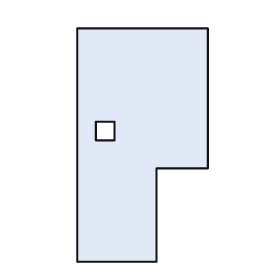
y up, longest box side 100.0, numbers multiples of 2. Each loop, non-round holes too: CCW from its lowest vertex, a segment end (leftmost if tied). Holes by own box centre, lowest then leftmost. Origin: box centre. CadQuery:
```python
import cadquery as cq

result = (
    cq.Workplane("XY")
    .moveTo(-28.0, -50.0)
    .lineTo(6.0, -50.0)
    .lineTo(6.0, -10.0)
    .lineTo(28.0, -10.0)
    .lineTo(28.0, 50.0)
    .lineTo(-28.0, 50.0)
    .close()
    .moveTo(-20.0, 2.0)
    .lineTo(-12.0, 2.0)
    .lineTo(-12.0, 10.0)
    .lineTo(-20.0, 10.0)
    .close()
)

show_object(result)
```